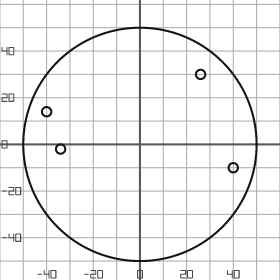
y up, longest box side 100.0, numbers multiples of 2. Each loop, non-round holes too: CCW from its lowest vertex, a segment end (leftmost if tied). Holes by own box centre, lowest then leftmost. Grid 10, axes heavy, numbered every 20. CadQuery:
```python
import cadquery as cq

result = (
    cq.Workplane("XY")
    .moveTo(0.0, 0.0)
    .circle(50.0)
    .moveTo(40.0, -10.0)
    .circle(2.0)
    .moveTo(-34.0, -2.0)
    .circle(2.0)
    .moveTo(-40.0, 14.0)
    .circle(2.0)
    .moveTo(26.0, 30.0)
    .circle(2.0)
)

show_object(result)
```